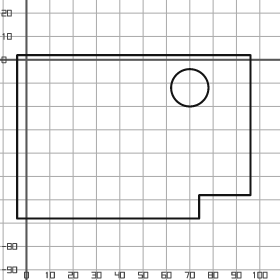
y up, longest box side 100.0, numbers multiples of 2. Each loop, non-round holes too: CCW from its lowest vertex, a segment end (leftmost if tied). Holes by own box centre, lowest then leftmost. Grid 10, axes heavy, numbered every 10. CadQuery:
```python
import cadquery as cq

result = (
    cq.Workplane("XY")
    .moveTo(-4.0, -68.0)
    .lineTo(74.0, -68.0)
    .lineTo(74.0, -58.0)
    .lineTo(96.0, -58.0)
    .lineTo(96.0, 2.0)
    .lineTo(-4.0, 2.0)
    .close()
    .moveTo(70.0, -12.0)
    .circle(8.0)
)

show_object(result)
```